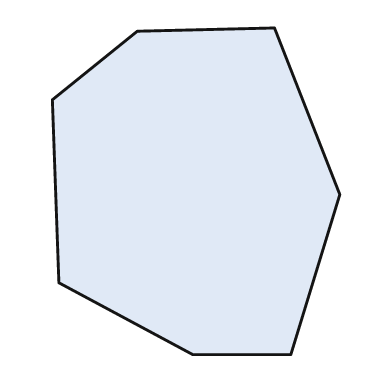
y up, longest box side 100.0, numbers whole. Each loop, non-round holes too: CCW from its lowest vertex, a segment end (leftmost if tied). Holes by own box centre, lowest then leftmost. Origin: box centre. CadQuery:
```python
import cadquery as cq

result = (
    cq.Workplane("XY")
    .moveTo(-1.0, -50.0)
    .lineTo(29.0, -50.0)
    .lineTo(44.0, -1.0)
    .lineTo(24.0, 50.0)
    .lineTo(-18.0, 49.0)
    .lineTo(-44.0, 28.0)
    .lineTo(-42.0, -28.0)
    .close()
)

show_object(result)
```